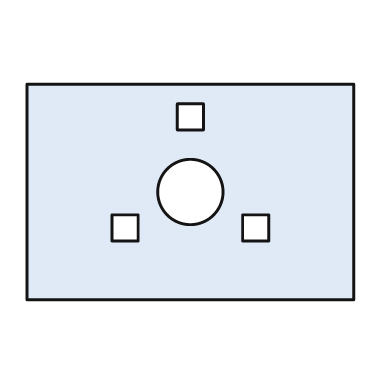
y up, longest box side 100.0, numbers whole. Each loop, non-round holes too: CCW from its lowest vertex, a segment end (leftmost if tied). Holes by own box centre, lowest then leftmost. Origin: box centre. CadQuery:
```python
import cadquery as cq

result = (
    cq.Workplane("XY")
    .moveTo(-50.0, -33.0)
    .lineTo(50.0, -33.0)
    .lineTo(50.0, 33.0)
    .lineTo(-50.0, 33.0)
    .close()
    .moveTo(-24.0, -15.0)
    .lineTo(-16.0, -15.0)
    .lineTo(-16.0, -7.0)
    .lineTo(-24.0, -7.0)
    .close()
    .moveTo(16.0, -15.0)
    .lineTo(24.0, -15.0)
    .lineTo(24.0, -7.0)
    .lineTo(16.0, -7.0)
    .close()
    .moveTo(0.0, 0.0)
    .circle(10.0)
    .moveTo(-4.0, 19.0)
    .lineTo(4.0, 19.0)
    .lineTo(4.0, 27.0)
    .lineTo(-4.0, 27.0)
    .close()
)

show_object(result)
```